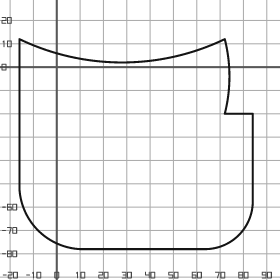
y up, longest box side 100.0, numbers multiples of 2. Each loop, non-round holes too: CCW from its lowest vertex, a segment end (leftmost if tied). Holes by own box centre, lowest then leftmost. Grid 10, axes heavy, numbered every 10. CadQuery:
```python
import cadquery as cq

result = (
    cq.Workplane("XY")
    .moveTo(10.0, -78.0)
    .lineTo(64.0, -78.0)
    .threePointArc((78.0, -72.0), (84.0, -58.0))
    .lineTo(84.0, -20.0)
    .lineTo(72.0, -20.0)
    .threePointArc((74.0, -4.0), (72.0, 12.0))
    .threePointArc((28.0, 2.0), (-16.0, 12.0))
    .lineTo(-16.0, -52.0)
    .threePointArc((-8.0, -70.0), (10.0, -78.0))
    .close()
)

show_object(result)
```